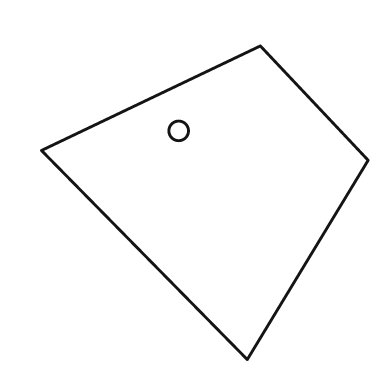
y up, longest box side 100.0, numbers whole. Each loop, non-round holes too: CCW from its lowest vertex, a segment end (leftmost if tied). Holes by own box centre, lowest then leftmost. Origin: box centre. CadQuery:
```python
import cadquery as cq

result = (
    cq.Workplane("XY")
    .moveTo(13.0, -48.0)
    .lineTo(50.0, 13.0)
    .lineTo(17.0, 48.0)
    .lineTo(-50.0, 16.0)
    .close()
    .moveTo(-8.0, 22.0)
    .circle(3.0)
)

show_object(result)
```